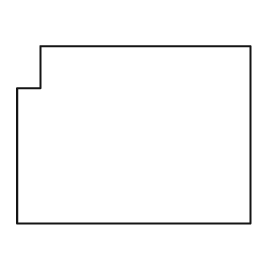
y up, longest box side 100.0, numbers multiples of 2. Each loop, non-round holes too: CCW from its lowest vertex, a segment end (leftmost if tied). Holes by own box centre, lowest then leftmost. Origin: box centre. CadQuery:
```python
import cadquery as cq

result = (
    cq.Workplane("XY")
    .moveTo(-50.0, -38.0)
    .lineTo(50.0, -38.0)
    .lineTo(50.0, 38.0)
    .lineTo(-40.0, 38.0)
    .lineTo(-40.0, 20.0)
    .lineTo(-50.0, 20.0)
    .close()
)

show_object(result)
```